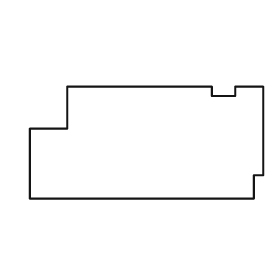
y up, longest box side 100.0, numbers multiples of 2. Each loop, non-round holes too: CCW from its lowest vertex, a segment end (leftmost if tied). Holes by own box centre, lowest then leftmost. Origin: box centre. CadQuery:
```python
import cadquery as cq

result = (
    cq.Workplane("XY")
    .moveTo(-50.0, -24.0)
    .lineTo(46.0, -24.0)
    .lineTo(46.0, -14.0)
    .lineTo(50.0, -14.0)
    .lineTo(50.0, 24.0)
    .lineTo(38.0, 24.0)
    .lineTo(38.0, 20.0)
    .lineTo(28.0, 20.0)
    .lineTo(28.0, 24.0)
    .lineTo(-34.0, 24.0)
    .lineTo(-34.0, 6.0)
    .lineTo(-50.0, 6.0)
    .close()
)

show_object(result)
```